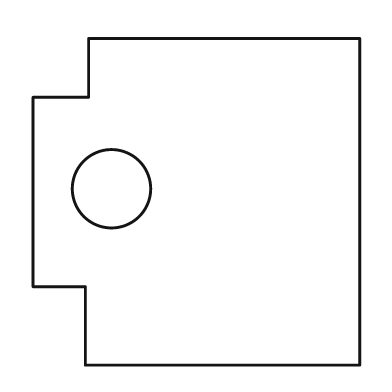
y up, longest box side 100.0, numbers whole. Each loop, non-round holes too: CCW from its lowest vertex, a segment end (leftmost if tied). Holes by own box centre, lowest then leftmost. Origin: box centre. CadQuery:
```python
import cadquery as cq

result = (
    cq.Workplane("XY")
    .moveTo(-34.0, -50.0)
    .lineTo(50.0, -50.0)
    .lineTo(50.0, 50.0)
    .lineTo(-33.0, 50.0)
    .lineTo(-33.0, 32.0)
    .lineTo(-50.0, 32.0)
    .lineTo(-50.0, -26.0)
    .lineTo(-34.0, -26.0)
    .close()
    .moveTo(-26.0, 4.0)
    .circle(12.0)
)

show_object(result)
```